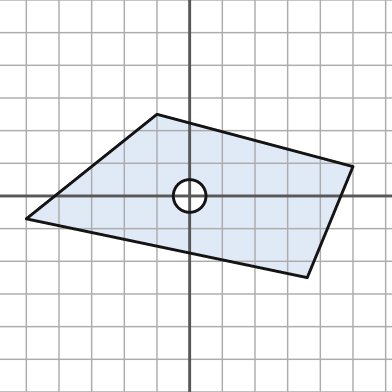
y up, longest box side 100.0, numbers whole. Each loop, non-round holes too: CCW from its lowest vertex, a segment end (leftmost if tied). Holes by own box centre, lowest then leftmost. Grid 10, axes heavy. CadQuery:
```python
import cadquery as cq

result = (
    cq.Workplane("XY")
    .moveTo(36.0, -25.0)
    .lineTo(50.0, 9.0)
    .lineTo(-10.0, 25.0)
    .lineTo(-50.0, -7.0)
    .close()
    .moveTo(0.0, 0.0)
    .circle(5.0)
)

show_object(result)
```